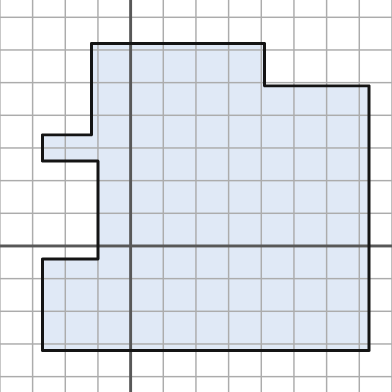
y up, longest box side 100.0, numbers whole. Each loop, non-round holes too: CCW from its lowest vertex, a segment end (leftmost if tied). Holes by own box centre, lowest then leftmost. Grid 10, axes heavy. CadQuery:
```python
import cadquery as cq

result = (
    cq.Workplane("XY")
    .moveTo(-27.0, -32.0)
    .lineTo(73.0, -32.0)
    .lineTo(73.0, 49.0)
    .lineTo(41.0, 49.0)
    .lineTo(41.0, 62.0)
    .lineTo(-12.0, 62.0)
    .lineTo(-12.0, 34.0)
    .lineTo(-27.0, 34.0)
    .lineTo(-27.0, 26.0)
    .lineTo(-10.0, 26.0)
    .lineTo(-10.0, -4.0)
    .lineTo(-27.0, -4.0)
    .close()
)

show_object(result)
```